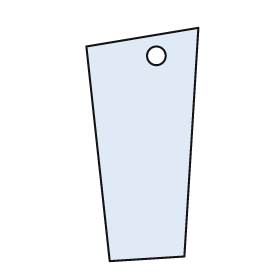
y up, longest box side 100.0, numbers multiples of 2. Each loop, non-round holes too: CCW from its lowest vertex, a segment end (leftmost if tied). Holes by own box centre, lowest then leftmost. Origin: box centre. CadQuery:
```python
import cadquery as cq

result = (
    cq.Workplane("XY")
    .moveTo(-14.0, -50.0)
    .lineTo(18.0, -48.0)
    .lineTo(24.0, 50.0)
    .lineTo(-24.0, 42.0)
    .close()
    .moveTo(6.0, 38.0)
    .circle(4.0)
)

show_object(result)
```